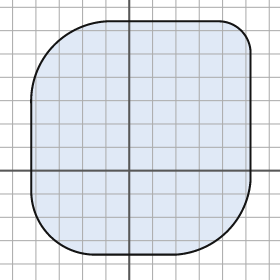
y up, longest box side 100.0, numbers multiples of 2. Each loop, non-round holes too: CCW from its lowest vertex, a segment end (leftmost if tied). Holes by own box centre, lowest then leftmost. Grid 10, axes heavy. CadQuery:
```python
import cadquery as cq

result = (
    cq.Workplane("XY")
    .moveTo(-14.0, -36.0)
    .lineTo(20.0, -36.0)
    .threePointArc((42.0, -26.0), (52.0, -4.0))
    .lineTo(52.0, 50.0)
    .threePointArc((48.0, 60.0), (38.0, 64.0))
    .lineTo(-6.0, 64.0)
    .threePointArc((-32.0, 54.0), (-42.0, 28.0))
    .lineTo(-42.0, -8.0)
    .threePointArc((-34.0, -28.0), (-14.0, -36.0))
    .close()
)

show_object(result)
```